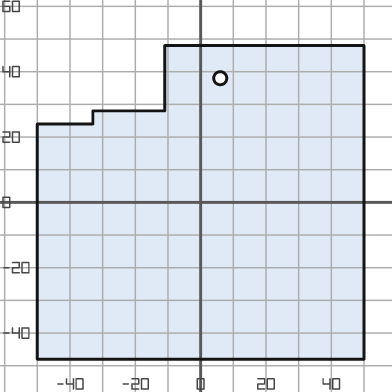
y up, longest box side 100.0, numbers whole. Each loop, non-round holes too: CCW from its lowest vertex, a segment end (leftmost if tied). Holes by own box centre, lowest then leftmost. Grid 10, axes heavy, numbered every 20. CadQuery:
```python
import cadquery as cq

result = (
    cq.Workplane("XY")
    .moveTo(-50.0, -48.0)
    .lineTo(50.0, -48.0)
    .lineTo(50.0, 48.0)
    .lineTo(-11.0, 48.0)
    .lineTo(-11.0, 28.0)
    .lineTo(-33.0, 28.0)
    .lineTo(-33.0, 24.0)
    .lineTo(-50.0, 24.0)
    .close()
    .moveTo(6.0, 38.0)
    .circle(2.0)
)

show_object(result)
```